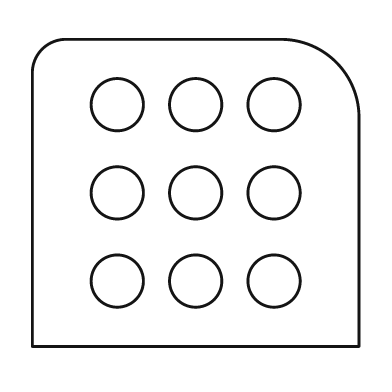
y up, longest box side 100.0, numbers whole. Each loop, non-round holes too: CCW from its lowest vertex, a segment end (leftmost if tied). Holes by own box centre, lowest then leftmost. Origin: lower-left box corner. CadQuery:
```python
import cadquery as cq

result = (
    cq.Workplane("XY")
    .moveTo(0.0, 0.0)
    .lineTo(100.0, 0.0)
    .lineTo(100.0, 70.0)
    .threePointArc((93.0, 87.0), (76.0, 94.0))
    .lineTo(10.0, 94.0)
    .threePointArc((3.0, 91.0), (0.0, 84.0))
    .close()
    .moveTo(26.0, 20.0)
    .circle(8.0)
    .moveTo(50.0, 20.0)
    .circle(8.0)
    .moveTo(74.0, 20.0)
    .circle(8.0)
    .moveTo(26.0, 47.0)
    .circle(8.0)
    .moveTo(50.0, 47.0)
    .circle(8.0)
    .moveTo(74.0, 47.0)
    .circle(8.0)
    .moveTo(26.0, 74.0)
    .circle(8.0)
    .moveTo(50.0, 74.0)
    .circle(8.0)
    .moveTo(74.0, 74.0)
    .circle(8.0)
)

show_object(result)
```